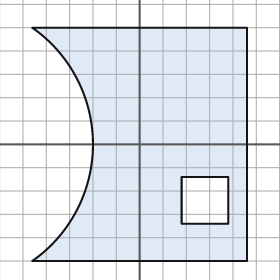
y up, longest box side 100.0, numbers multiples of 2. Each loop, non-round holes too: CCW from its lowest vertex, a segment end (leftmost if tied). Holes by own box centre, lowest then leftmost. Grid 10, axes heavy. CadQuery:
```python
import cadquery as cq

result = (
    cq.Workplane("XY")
    .moveTo(-46.0, -50.0)
    .lineTo(46.0, -50.0)
    .lineTo(46.0, 50.0)
    .lineTo(-46.0, 50.0)
    .threePointArc((-20.0, 0.0), (-46.0, -50.0))
    .close()
    .moveTo(18.0, -34.0)
    .lineTo(38.0, -34.0)
    .lineTo(38.0, -14.0)
    .lineTo(18.0, -14.0)
    .close()
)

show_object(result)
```